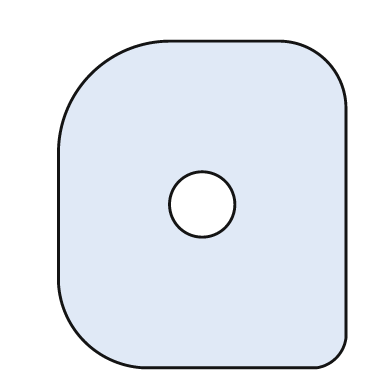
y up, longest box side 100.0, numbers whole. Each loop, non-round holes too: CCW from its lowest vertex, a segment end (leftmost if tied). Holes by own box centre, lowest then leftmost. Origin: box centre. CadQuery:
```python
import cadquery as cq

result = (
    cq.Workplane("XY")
    .moveTo(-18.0, -50.0)
    .lineTo(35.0, -50.0)
    .threePointArc((41.0, -47.0), (44.0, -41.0))
    .lineTo(44.0, 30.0)
    .threePointArc((38.0, 44.0), (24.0, 50.0))
    .lineTo(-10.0, 50.0)
    .threePointArc((-34.0, 40.0), (-44.0, 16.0))
    .lineTo(-44.0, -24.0)
    .threePointArc((-36.0, -42.0), (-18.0, -50.0))
    .close()
    .moveTo(0.0, 0.0)
    .circle(10.0)
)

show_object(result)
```